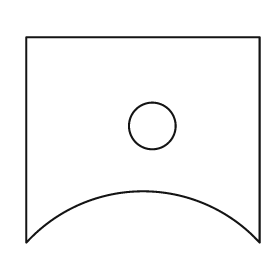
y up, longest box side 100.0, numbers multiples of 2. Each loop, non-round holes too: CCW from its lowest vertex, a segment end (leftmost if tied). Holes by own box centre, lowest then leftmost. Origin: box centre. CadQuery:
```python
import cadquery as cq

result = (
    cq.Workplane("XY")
    .moveTo(-50.0, -44.0)
    .threePointArc((0.0, -22.0), (50.0, -44.0))
    .lineTo(50.0, 44.0)
    .lineTo(-50.0, 44.0)
    .close()
    .moveTo(4.0, 6.0)
    .circle(10.0)
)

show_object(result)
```